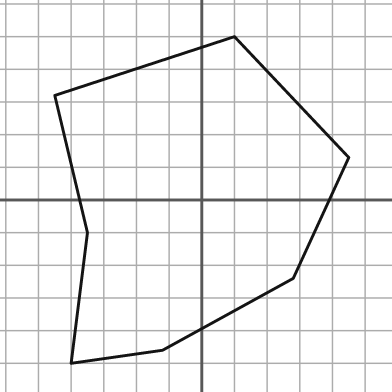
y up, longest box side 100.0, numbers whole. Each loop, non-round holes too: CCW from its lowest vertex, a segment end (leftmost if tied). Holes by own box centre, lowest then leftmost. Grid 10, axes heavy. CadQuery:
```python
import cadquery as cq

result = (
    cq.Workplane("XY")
    .moveTo(-40.0, -50.0)
    .lineTo(-12.0, -46.0)
    .lineTo(28.0, -24.0)
    .lineTo(45.0, 13.0)
    .lineTo(10.0, 50.0)
    .lineTo(-45.0, 32.0)
    .lineTo(-35.0, -10.0)
    .close()
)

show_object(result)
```